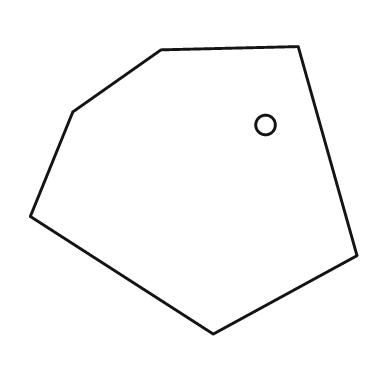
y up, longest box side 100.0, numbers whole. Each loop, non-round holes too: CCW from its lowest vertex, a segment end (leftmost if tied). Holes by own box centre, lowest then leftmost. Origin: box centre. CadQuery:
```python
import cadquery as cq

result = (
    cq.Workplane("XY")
    .moveTo(6.0, -44.0)
    .lineTo(50.0, -20.0)
    .lineTo(32.0, 44.0)
    .lineTo(-10.0, 43.0)
    .lineTo(-37.0, 24.0)
    .lineTo(-50.0, -8.0)
    .close()
    .moveTo(22.0, 20.0)
    .circle(3.0)
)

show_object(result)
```